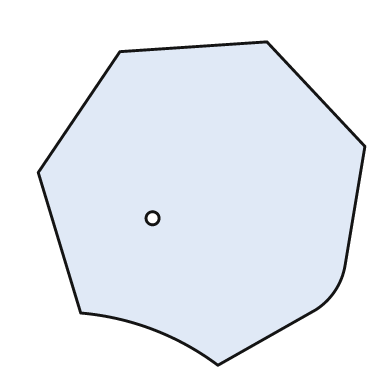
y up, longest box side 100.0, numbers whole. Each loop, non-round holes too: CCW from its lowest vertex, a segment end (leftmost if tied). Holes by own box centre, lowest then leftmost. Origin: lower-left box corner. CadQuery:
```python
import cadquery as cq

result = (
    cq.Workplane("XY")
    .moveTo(55.0, 0.0)
    .lineTo(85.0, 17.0)
    .threePointArc((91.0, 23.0), (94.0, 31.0))
    .lineTo(100.0, 67.0)
    .lineTo(70.0, 99.0)
    .lineTo(25.0, 96.0)
    .lineTo(0.0, 59.0)
    .lineTo(13.0, 16.0)
    .threePointArc((35.0, 11.0), (55.0, 0.0))
    .close()
    .moveTo(35.0, 45.0)
    .circle(2.0)
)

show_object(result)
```